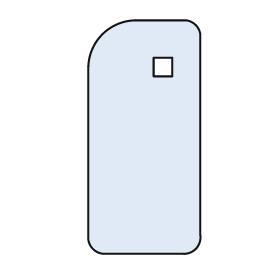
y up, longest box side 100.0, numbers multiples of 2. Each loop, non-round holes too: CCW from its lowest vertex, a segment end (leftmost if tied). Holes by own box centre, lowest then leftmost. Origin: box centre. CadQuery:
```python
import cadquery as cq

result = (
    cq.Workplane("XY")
    .moveTo(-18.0, -50.0)
    .lineTo(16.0, -50.0)
    .threePointArc((22.0, -48.0), (24.0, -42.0))
    .lineTo(24.0, 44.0)
    .threePointArc((22.0, 48.0), (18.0, 50.0))
    .lineTo(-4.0, 50.0)
    .threePointArc((-18.0, 44.0), (-24.0, 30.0))
    .lineTo(-24.0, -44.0)
    .threePointArc((-22.0, -48.0), (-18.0, -50.0))
    .close()
    .moveTo(4.0, 26.0)
    .lineTo(12.0, 26.0)
    .lineTo(12.0, 34.0)
    .lineTo(4.0, 34.0)
    .close()
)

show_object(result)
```